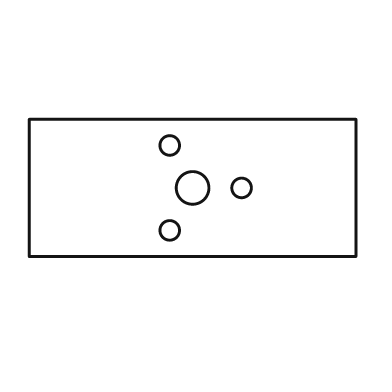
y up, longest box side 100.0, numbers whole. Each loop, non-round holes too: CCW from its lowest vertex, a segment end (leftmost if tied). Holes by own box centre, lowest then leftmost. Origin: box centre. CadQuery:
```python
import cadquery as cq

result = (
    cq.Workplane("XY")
    .moveTo(-50.0, -21.0)
    .lineTo(50.0, -21.0)
    .lineTo(50.0, 21.0)
    .lineTo(-50.0, 21.0)
    .close()
    .moveTo(-7.0, -13.0)
    .circle(3.0)
    .moveTo(0.0, 0.0)
    .circle(5.0)
    .moveTo(15.0, 0.0)
    .circle(3.0)
    .moveTo(-7.0, 13.0)
    .circle(3.0)
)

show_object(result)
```